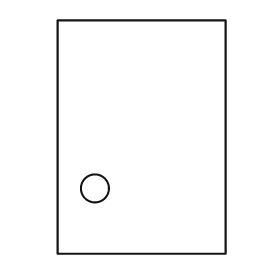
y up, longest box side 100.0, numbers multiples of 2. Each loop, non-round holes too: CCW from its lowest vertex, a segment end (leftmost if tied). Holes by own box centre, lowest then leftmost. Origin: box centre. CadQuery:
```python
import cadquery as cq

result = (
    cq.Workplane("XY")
    .moveTo(-36.0, -50.0)
    .lineTo(36.0, -50.0)
    .lineTo(36.0, 50.0)
    .lineTo(-36.0, 50.0)
    .close()
    .moveTo(-20.0, -22.0)
    .circle(6.0)
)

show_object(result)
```